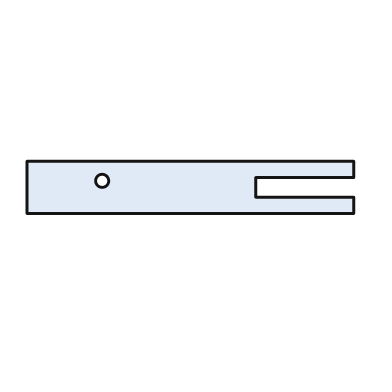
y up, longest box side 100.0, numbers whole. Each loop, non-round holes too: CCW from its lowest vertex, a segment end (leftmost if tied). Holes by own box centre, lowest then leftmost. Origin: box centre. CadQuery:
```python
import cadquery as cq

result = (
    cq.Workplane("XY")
    .moveTo(-50.0, -8.0)
    .lineTo(50.0, -8.0)
    .lineTo(50.0, -3.0)
    .lineTo(20.0, -3.0)
    .lineTo(20.0, 3.0)
    .lineTo(50.0, 3.0)
    .lineTo(50.0, 8.0)
    .lineTo(-50.0, 8.0)
    .close()
    .moveTo(-27.0, 2.0)
    .circle(2.0)
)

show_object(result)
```